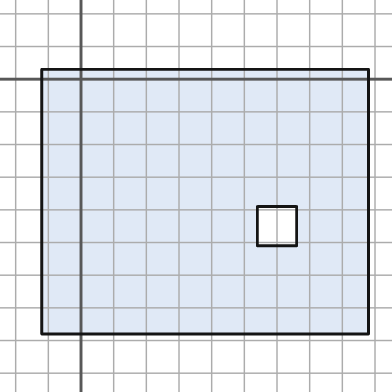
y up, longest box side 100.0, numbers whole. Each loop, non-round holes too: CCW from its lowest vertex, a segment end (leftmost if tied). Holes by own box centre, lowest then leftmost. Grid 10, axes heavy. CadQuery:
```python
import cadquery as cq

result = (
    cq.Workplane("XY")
    .moveTo(-12.0, -78.0)
    .lineTo(88.0, -78.0)
    .lineTo(88.0, 3.0)
    .lineTo(-12.0, 3.0)
    .close()
    .moveTo(54.0, -51.0)
    .lineTo(66.0, -51.0)
    .lineTo(66.0, -39.0)
    .lineTo(54.0, -39.0)
    .close()
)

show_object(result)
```